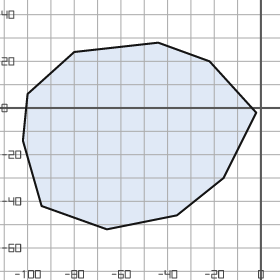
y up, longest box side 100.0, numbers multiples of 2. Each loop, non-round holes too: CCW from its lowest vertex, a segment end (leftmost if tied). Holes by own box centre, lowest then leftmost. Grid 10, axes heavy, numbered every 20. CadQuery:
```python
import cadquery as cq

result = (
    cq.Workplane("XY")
    .moveTo(-66.0, -52.0)
    .lineTo(-36.0, -46.0)
    .lineTo(-16.0, -30.0)
    .lineTo(-2.0, -2.0)
    .lineTo(-22.0, 20.0)
    .lineTo(-44.0, 28.0)
    .lineTo(-80.0, 24.0)
    .lineTo(-100.0, 6.0)
    .lineTo(-102.0, -14.0)
    .lineTo(-94.0, -42.0)
    .close()
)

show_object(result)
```